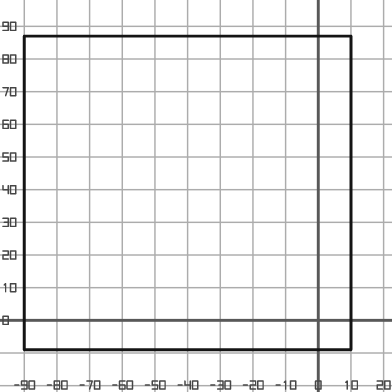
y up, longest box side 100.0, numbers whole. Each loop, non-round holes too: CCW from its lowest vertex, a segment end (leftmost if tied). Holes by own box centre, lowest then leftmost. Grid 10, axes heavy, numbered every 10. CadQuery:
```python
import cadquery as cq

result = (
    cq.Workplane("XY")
    .moveTo(-90.0, -9.0)
    .lineTo(10.0, -9.0)
    .lineTo(10.0, 87.0)
    .lineTo(-90.0, 87.0)
    .close()
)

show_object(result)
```